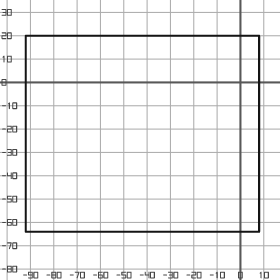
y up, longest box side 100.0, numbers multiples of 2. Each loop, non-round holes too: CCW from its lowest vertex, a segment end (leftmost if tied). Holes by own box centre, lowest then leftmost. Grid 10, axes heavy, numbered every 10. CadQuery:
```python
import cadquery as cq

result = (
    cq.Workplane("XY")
    .moveTo(-92.0, -64.0)
    .lineTo(8.0, -64.0)
    .lineTo(8.0, 20.0)
    .lineTo(-92.0, 20.0)
    .close()
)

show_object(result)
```